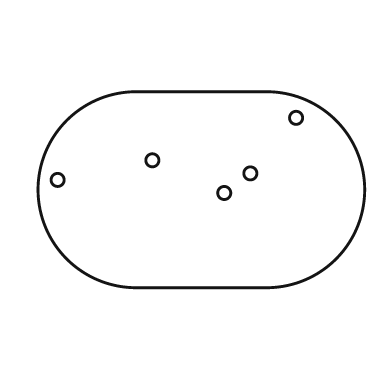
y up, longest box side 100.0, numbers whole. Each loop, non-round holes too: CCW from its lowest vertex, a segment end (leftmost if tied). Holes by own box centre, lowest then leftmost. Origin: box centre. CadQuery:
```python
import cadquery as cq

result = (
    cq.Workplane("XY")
    .moveTo(-20.0, -30.0)
    .lineTo(20.0, -30.0)
    .threePointArc((50.0, 0.0), (20.0, 30.0))
    .lineTo(-20.0, 30.0)
    .threePointArc((-50.0, 0.0), (-20.0, -30.0))
    .close()
    .moveTo(7.0, -1.0)
    .circle(2.0)
    .moveTo(-44.0, 3.0)
    .circle(2.0)
    .moveTo(15.0, 5.0)
    .circle(2.0)
    .moveTo(-15.0, 9.0)
    .circle(2.0)
    .moveTo(29.0, 22.0)
    .circle(2.0)
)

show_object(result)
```